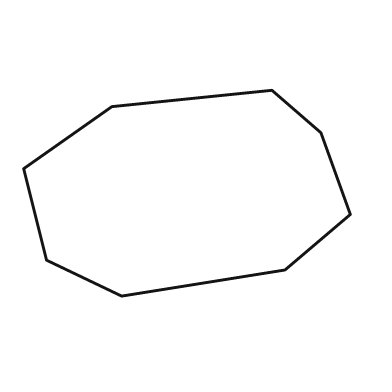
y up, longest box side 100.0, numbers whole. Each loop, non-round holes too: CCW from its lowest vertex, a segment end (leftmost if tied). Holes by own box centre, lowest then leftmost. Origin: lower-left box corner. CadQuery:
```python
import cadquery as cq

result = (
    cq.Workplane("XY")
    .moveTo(30.0, 0.0)
    .lineTo(80.0, 8.0)
    .lineTo(100.0, 25.0)
    .lineTo(91.0, 50.0)
    .lineTo(76.0, 63.0)
    .lineTo(27.0, 58.0)
    .lineTo(0.0, 39.0)
    .lineTo(7.0, 11.0)
    .close()
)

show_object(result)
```